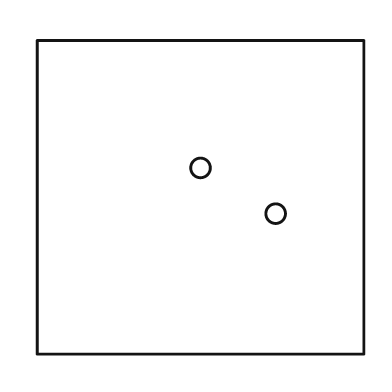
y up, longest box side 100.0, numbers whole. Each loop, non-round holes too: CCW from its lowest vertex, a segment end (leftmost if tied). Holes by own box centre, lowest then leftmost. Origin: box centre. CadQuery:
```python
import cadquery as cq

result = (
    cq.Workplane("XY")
    .moveTo(-50.0, -48.0)
    .lineTo(50.0, -48.0)
    .lineTo(50.0, 48.0)
    .lineTo(-50.0, 48.0)
    .close()
    .moveTo(23.0, -5.0)
    .circle(3.0)
    .moveTo(0.0, 9.0)
    .circle(3.0)
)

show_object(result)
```